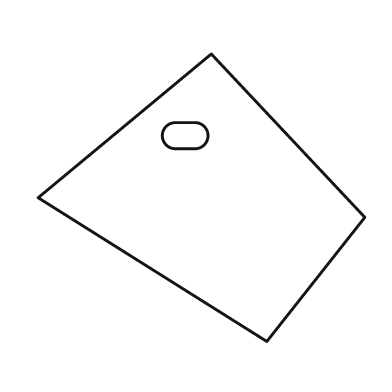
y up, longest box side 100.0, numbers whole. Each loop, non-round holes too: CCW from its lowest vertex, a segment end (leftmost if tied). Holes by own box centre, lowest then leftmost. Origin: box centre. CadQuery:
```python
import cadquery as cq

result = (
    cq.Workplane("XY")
    .moveTo(20.0, -44.0)
    .lineTo(50.0, -6.0)
    .lineTo(3.0, 44.0)
    .lineTo(-50.0, 0.0)
    .close()
    .moveTo(-8.0, 15.0)
    .lineTo(-2.0, 15.0)
    .threePointArc((2.0, 19.0), (-2.0, 23.0))
    .lineTo(-8.0, 23.0)
    .threePointArc((-12.0, 19.0), (-8.0, 15.0))
    .close()
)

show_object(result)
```